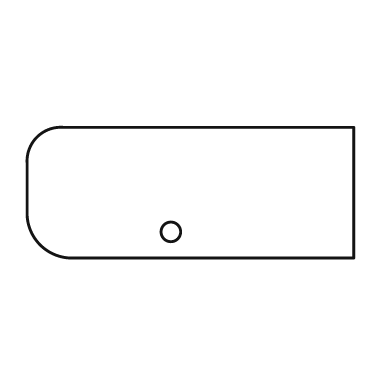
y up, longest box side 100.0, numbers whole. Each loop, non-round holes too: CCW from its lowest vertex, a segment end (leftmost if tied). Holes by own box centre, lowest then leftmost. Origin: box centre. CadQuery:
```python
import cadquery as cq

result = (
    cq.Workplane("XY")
    .moveTo(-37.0, -20.0)
    .lineTo(50.0, -20.0)
    .lineTo(50.0, 20.0)
    .lineTo(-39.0, 20.0)
    .threePointArc((-47.0, 17.0), (-50.0, 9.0))
    .lineTo(-50.0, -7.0)
    .threePointArc((-46.0, -16.0), (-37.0, -20.0))
    .close()
    .moveTo(-6.0, -12.0)
    .circle(3.0)
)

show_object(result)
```